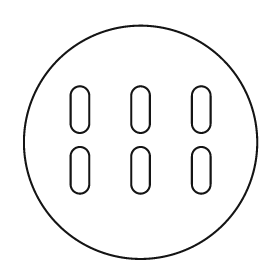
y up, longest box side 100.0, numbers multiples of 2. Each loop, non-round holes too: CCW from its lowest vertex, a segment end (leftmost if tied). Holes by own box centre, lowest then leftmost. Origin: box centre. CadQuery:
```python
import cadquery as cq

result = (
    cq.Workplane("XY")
    .moveTo(0.0, 0.0)
    .circle(50.0)
    .moveTo(-30.0, -18.0)
    .threePointArc((-26.0, -22.0), (-22.0, -18.0))
    .lineTo(-22.0, -6.0)
    .threePointArc((-26.0, -2.0), (-30.0, -6.0))
    .close()
    .moveTo(-4.0, -18.0)
    .threePointArc((0.0, -22.0), (4.0, -18.0))
    .lineTo(4.0, -6.0)
    .threePointArc((0.0, -2.0), (-4.0, -6.0))
    .close()
    .moveTo(22.0, -18.0)
    .threePointArc((26.0, -22.0), (30.0, -18.0))
    .lineTo(30.0, -6.0)
    .threePointArc((26.0, -2.0), (22.0, -6.0))
    .close()
    .moveTo(-30.0, 8.0)
    .threePointArc((-26.0, 4.0), (-22.0, 8.0))
    .lineTo(-22.0, 20.0)
    .threePointArc((-26.0, 24.0), (-30.0, 20.0))
    .close()
    .moveTo(-4.0, 8.0)
    .threePointArc((0.0, 4.0), (4.0, 8.0))
    .lineTo(4.0, 20.0)
    .threePointArc((0.0, 24.0), (-4.0, 20.0))
    .close()
    .moveTo(22.0, 8.0)
    .threePointArc((26.0, 4.0), (30.0, 8.0))
    .lineTo(30.0, 20.0)
    .threePointArc((26.0, 24.0), (22.0, 20.0))
    .close()
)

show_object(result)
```